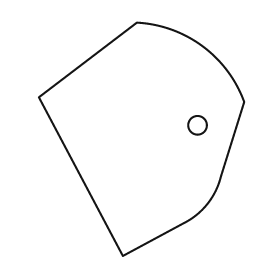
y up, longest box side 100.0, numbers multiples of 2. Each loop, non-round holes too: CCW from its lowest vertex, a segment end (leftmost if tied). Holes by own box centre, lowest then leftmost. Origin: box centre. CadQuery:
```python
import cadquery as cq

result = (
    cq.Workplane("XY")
    .moveTo(-8.0, -50.0)
    .lineTo(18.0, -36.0)
    .threePointArc((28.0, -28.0), (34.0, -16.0))
    .lineTo(44.0, 16.0)
    .threePointArc((26.0, 40.0), (-2.0, 50.0))
    .lineTo(-44.0, 18.0)
    .close()
    .moveTo(24.0, 6.0)
    .circle(4.0)
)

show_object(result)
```